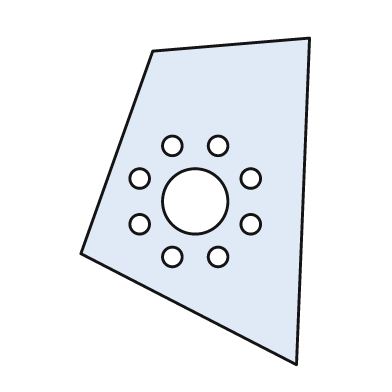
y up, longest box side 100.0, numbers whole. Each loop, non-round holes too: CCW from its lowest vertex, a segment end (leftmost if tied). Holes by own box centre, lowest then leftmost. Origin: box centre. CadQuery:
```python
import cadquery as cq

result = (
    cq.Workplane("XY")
    .moveTo(31.0, -50.0)
    .lineTo(35.0, 50.0)
    .lineTo(-13.0, 46.0)
    .lineTo(-35.0, -16.0)
    .close()
    .moveTo(-7.0, -17.0)
    .circle(3.0)
    .moveTo(7.0, -17.0)
    .circle(3.0)
    .moveTo(-17.0, -7.0)
    .circle(3.0)
    .moveTo(17.0, -7.0)
    .circle(3.0)
    .moveTo(0.0, 0.0)
    .circle(10.0)
    .moveTo(-17.0, 7.0)
    .circle(3.0)
    .moveTo(17.0, 7.0)
    .circle(3.0)
    .moveTo(-7.0, 17.0)
    .circle(3.0)
    .moveTo(7.0, 17.0)
    .circle(3.0)
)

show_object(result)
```